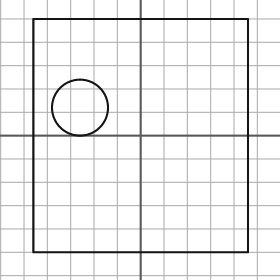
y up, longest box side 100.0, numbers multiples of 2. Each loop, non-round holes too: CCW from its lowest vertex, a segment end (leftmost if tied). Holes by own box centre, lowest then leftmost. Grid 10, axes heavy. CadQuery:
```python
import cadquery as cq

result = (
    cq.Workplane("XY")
    .moveTo(-46.0, -50.0)
    .lineTo(46.0, -50.0)
    .lineTo(46.0, 50.0)
    .lineTo(-46.0, 50.0)
    .close()
    .moveTo(-26.0, 12.0)
    .circle(12.0)
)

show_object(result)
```